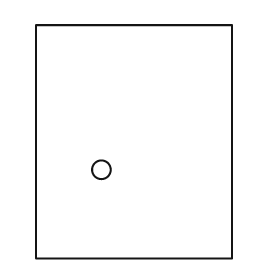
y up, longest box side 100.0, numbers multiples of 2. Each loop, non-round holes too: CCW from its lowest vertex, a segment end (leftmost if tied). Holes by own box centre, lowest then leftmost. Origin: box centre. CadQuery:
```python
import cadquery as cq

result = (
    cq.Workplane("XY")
    .moveTo(-42.0, -50.0)
    .lineTo(42.0, -50.0)
    .lineTo(42.0, 50.0)
    .lineTo(-42.0, 50.0)
    .close()
    .moveTo(-14.0, -12.0)
    .circle(4.0)
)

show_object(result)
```